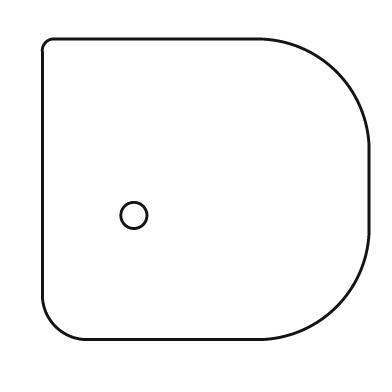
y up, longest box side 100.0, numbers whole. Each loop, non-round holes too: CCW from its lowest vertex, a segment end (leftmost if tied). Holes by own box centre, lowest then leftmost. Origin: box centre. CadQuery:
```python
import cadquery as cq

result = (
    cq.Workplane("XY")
    .moveTo(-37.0, -46.0)
    .lineTo(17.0, -46.0)
    .threePointArc((40.0, -36.0), (50.0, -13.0))
    .lineTo(50.0, 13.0)
    .threePointArc((40.0, 36.0), (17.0, 46.0))
    .lineTo(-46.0, 46.0)
    .threePointArc((-49.0, 45.0), (-50.0, 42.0))
    .lineTo(-50.0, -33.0)
    .threePointArc((-46.0, -42.0), (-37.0, -46.0))
    .close()
    .moveTo(-22.0, -8.0)
    .circle(4.0)
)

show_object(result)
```